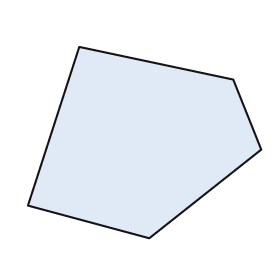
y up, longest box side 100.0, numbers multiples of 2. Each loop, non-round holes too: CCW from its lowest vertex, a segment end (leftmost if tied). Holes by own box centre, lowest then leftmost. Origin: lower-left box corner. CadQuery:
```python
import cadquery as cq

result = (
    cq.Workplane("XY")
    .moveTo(52.0, 0.0)
    .lineTo(100.0, 38.0)
    .lineTo(88.0, 68.0)
    .lineTo(22.0, 82.0)
    .lineTo(0.0, 14.0)
    .close()
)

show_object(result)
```